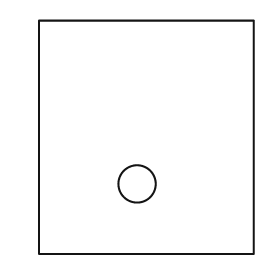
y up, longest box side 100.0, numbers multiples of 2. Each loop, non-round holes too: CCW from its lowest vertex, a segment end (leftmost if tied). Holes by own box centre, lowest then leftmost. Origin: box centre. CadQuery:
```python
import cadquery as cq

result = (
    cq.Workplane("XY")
    .moveTo(-46.0, -50.0)
    .lineTo(46.0, -50.0)
    .lineTo(46.0, 50.0)
    .lineTo(-46.0, 50.0)
    .close()
    .moveTo(-4.0, -20.0)
    .circle(8.0)
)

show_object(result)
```